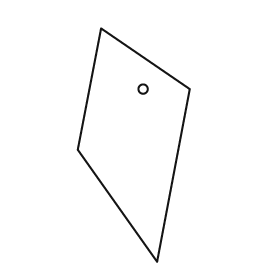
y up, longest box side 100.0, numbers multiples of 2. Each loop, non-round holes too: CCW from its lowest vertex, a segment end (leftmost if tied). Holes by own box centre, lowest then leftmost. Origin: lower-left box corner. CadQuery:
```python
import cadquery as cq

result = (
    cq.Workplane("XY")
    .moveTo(34.0, 0.0)
    .lineTo(48.0, 74.0)
    .lineTo(10.0, 100.0)
    .lineTo(0.0, 48.0)
    .close()
    .moveTo(28.0, 74.0)
    .circle(2.0)
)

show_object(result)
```